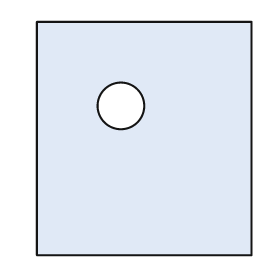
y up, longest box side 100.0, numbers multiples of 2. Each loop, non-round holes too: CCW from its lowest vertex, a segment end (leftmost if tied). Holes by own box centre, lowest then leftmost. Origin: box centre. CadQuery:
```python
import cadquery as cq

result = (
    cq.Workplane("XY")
    .moveTo(-46.0, -50.0)
    .lineTo(46.0, -50.0)
    .lineTo(46.0, 50.0)
    .lineTo(-46.0, 50.0)
    .close()
    .moveTo(-10.0, 14.0)
    .circle(10.0)
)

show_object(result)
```